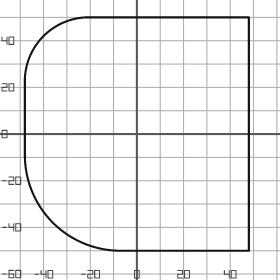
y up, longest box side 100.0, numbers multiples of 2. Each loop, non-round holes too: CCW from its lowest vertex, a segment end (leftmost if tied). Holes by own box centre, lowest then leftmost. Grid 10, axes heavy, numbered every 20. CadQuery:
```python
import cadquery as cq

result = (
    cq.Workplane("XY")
    .moveTo(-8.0, -50.0)
    .lineTo(48.0, -50.0)
    .lineTo(48.0, 50.0)
    .lineTo(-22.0, 50.0)
    .threePointArc((-40.0, 42.0), (-48.0, 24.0))
    .lineTo(-48.0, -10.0)
    .threePointArc((-36.0, -38.0), (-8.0, -50.0))
    .close()
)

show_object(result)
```